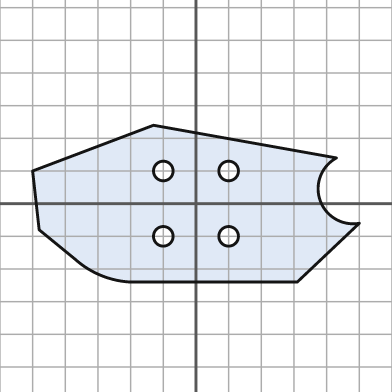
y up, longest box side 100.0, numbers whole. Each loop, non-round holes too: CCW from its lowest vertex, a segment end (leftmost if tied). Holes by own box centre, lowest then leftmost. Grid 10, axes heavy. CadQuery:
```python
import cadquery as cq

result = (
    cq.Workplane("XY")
    .moveTo(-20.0, -24.0)
    .lineTo(31.0, -24.0)
    .lineTo(50.0, -6.0)
    .threePointArc((38.0, 1.0), (43.0, 14.0))
    .lineTo(-13.0, 24.0)
    .lineTo(-50.0, 10.0)
    .lineTo(-48.0, -8.0)
    .lineTo(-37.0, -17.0)
    .threePointArc((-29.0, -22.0), (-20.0, -24.0))
    .close()
    .moveTo(-10.0, -10.0)
    .circle(3.0)
    .moveTo(10.0, -10.0)
    .circle(3.0)
    .moveTo(-10.0, 10.0)
    .circle(3.0)
    .moveTo(10.0, 10.0)
    .circle(3.0)
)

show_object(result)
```